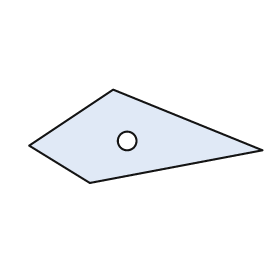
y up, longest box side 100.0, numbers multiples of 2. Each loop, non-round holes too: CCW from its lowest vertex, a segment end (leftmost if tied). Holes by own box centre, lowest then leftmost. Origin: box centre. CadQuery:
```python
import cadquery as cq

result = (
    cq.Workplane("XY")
    .moveTo(-24.0, -20.0)
    .lineTo(50.0, -6.0)
    .lineTo(-14.0, 20.0)
    .lineTo(-50.0, -4.0)
    .close()
    .moveTo(-8.0, -2.0)
    .circle(4.0)
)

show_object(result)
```